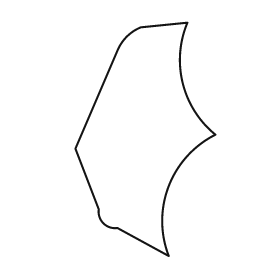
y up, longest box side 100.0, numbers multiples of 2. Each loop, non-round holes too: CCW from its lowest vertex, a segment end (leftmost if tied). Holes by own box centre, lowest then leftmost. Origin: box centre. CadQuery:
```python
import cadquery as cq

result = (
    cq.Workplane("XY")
    .moveTo(10.0, -50.0)
    .threePointArc((10.0, -20.0), (30.0, 2.0))
    .threePointArc((16.0, 24.0), (18.0, 50.0))
    .lineTo(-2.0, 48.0)
    .threePointArc((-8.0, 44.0), (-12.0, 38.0))
    .lineTo(-30.0, -4.0)
    .lineTo(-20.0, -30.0)
    .threePointArc((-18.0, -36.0), (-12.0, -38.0))
    .close()
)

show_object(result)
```